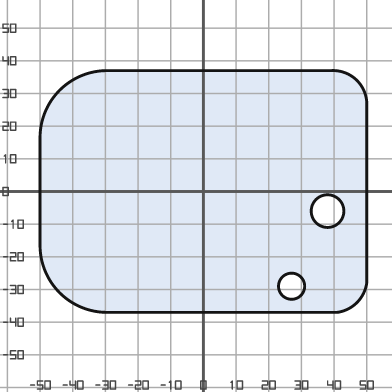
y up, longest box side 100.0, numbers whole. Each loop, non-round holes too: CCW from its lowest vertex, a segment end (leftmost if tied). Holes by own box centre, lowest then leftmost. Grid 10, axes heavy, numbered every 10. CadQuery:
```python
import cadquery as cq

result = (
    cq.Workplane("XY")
    .moveTo(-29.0, -37.0)
    .lineTo(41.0, -37.0)
    .threePointArc((47.0, -34.0), (50.0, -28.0))
    .lineTo(50.0, 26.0)
    .threePointArc((47.0, 34.0), (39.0, 37.0))
    .lineTo(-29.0, 37.0)
    .threePointArc((-44.0, 31.0), (-50.0, 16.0))
    .lineTo(-50.0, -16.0)
    .threePointArc((-44.0, -31.0), (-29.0, -37.0))
    .close()
    .moveTo(27.0, -29.0)
    .circle(4.0)
    .moveTo(38.0, -6.0)
    .circle(5.0)
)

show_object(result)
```